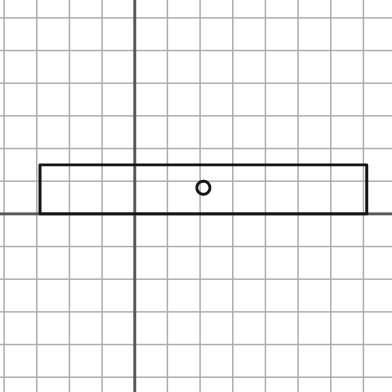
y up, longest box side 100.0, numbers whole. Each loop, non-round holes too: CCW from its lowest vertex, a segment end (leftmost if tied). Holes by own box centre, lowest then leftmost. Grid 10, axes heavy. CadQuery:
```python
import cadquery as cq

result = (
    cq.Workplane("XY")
    .moveTo(-29.0, 0.0)
    .lineTo(71.0, 0.0)
    .lineTo(71.0, 15.0)
    .lineTo(-29.0, 15.0)
    .close()
    .moveTo(21.0, 8.0)
    .circle(2.0)
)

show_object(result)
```